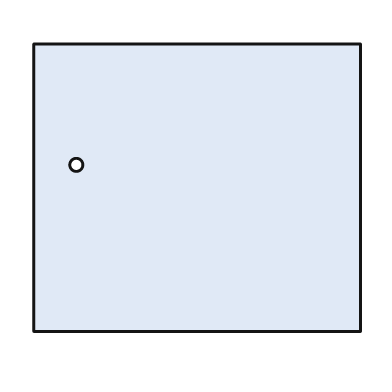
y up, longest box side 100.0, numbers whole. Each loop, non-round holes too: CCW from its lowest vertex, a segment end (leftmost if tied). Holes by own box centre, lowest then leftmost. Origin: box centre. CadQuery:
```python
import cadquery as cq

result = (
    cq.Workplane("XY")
    .moveTo(-50.0, -44.0)
    .lineTo(50.0, -44.0)
    .lineTo(50.0, 44.0)
    .lineTo(-50.0, 44.0)
    .close()
    .moveTo(-37.0, 7.0)
    .circle(2.0)
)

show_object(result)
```